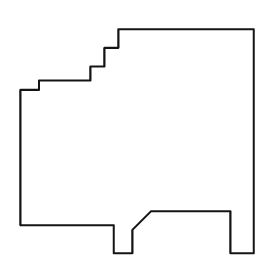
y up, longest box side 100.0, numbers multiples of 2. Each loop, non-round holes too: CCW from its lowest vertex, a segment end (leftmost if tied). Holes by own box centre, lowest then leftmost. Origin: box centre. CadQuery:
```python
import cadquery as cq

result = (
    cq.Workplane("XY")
    .moveTo(-10.0, -48.0)
    .lineTo(-2.0, -48.0)
    .lineTo(-2.0, -38.0)
    .lineTo(6.0, -30.0)
    .lineTo(40.0, -30.0)
    .lineTo(40.0, -48.0)
    .lineTo(50.0, -48.0)
    .lineTo(50.0, 48.0)
    .lineTo(-8.0, 48.0)
    .lineTo(-8.0, 40.0)
    .lineTo(-14.0, 40.0)
    .lineTo(-14.0, 32.0)
    .lineTo(-20.0, 32.0)
    .lineTo(-20.0, 26.0)
    .lineTo(-42.0, 26.0)
    .lineTo(-42.0, 22.0)
    .lineTo(-50.0, 22.0)
    .lineTo(-50.0, -36.0)
    .lineTo(-10.0, -36.0)
    .close()
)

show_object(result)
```